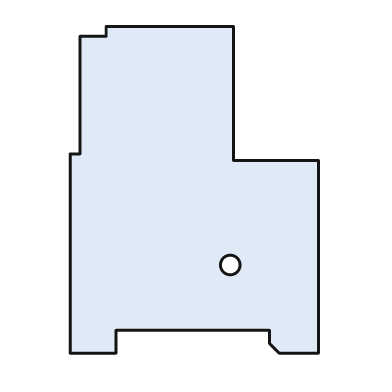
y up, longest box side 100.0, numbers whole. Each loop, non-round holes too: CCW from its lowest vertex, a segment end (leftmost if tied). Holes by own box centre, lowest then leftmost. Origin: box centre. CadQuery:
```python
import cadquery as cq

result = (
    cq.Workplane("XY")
    .moveTo(-38.0, -50.0)
    .lineTo(-24.0, -50.0)
    .lineTo(-24.0, -43.0)
    .lineTo(23.0, -43.0)
    .lineTo(23.0, -47.0)
    .lineTo(26.0, -50.0)
    .lineTo(38.0, -50.0)
    .lineTo(38.0, 9.0)
    .lineTo(12.0, 9.0)
    .lineTo(12.0, 50.0)
    .lineTo(-27.0, 50.0)
    .lineTo(-27.0, 47.0)
    .lineTo(-35.0, 47.0)
    .lineTo(-35.0, 11.0)
    .lineTo(-38.0, 11.0)
    .close()
    .moveTo(11.0, -23.0)
    .circle(3.0)
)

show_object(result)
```